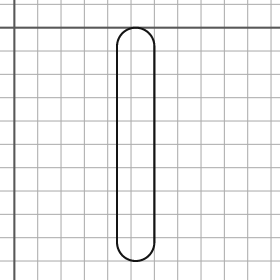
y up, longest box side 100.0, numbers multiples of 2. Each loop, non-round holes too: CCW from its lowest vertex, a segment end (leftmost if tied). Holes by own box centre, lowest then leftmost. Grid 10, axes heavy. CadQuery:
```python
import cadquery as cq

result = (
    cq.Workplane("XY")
    .moveTo(44.0, -92.0)
    .threePointArc((52.0, -100.0), (60.0, -92.0))
    .lineTo(60.0, -8.0)
    .threePointArc((52.0, 0.0), (44.0, -8.0))
    .close()
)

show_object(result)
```